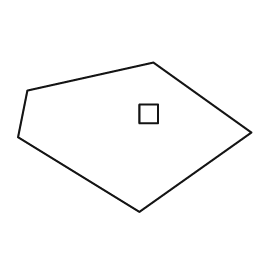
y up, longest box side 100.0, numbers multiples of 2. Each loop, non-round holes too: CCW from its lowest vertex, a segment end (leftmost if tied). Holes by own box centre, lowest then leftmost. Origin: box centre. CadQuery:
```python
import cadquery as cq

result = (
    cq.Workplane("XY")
    .moveTo(2.0, -32.0)
    .lineTo(50.0, 2.0)
    .lineTo(8.0, 32.0)
    .lineTo(-46.0, 20.0)
    .lineTo(-50.0, 0.0)
    .close()
    .moveTo(2.0, 6.0)
    .lineTo(10.0, 6.0)
    .lineTo(10.0, 14.0)
    .lineTo(2.0, 14.0)
    .close()
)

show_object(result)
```